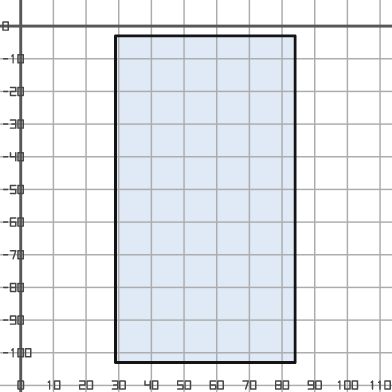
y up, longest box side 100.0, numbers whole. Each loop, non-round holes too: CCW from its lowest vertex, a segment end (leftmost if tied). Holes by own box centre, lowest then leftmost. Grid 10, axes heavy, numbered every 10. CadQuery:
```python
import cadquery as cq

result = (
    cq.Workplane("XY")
    .moveTo(29.0, -103.0)
    .lineTo(84.0, -103.0)
    .lineTo(84.0, -3.0)
    .lineTo(29.0, -3.0)
    .close()
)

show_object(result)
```